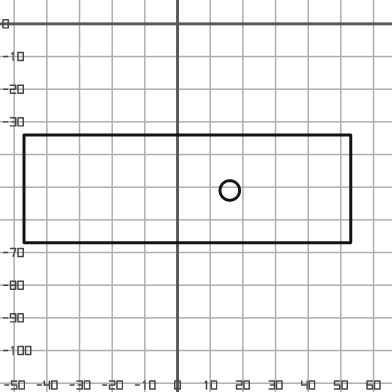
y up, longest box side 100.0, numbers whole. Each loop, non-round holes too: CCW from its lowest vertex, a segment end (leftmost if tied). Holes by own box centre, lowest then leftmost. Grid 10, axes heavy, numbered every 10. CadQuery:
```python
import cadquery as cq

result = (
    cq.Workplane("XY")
    .moveTo(-47.0, -67.0)
    .lineTo(53.0, -67.0)
    .lineTo(53.0, -34.0)
    .lineTo(-47.0, -34.0)
    .close()
    .moveTo(16.0, -51.0)
    .circle(3.0)
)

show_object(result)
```